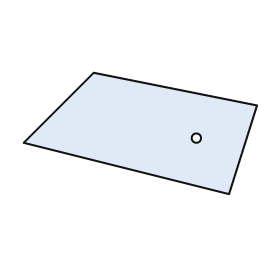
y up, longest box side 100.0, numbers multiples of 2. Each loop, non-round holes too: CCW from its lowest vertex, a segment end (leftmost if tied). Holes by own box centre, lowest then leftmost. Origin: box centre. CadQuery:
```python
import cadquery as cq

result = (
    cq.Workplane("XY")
    .moveTo(38.0, -26.0)
    .lineTo(50.0, 12.0)
    .lineTo(-20.0, 26.0)
    .lineTo(-50.0, -4.0)
    .close()
    .moveTo(24.0, -2.0)
    .circle(2.0)
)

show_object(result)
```